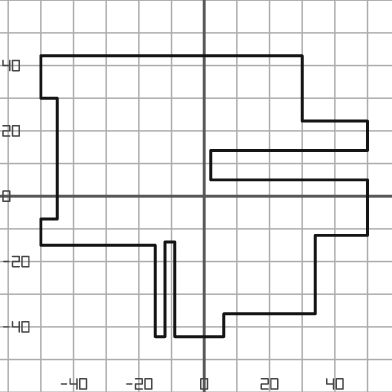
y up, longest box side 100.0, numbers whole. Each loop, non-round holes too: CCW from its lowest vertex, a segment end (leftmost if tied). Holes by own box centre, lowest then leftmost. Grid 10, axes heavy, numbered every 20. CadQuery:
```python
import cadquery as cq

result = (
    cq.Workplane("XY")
    .moveTo(-15.0, -43.0)
    .lineTo(-12.0, -43.0)
    .lineTo(-12.0, -14.0)
    .lineTo(-9.0, -14.0)
    .lineTo(-9.0, -43.0)
    .lineTo(6.0, -43.0)
    .lineTo(6.0, -36.0)
    .lineTo(34.0, -36.0)
    .lineTo(34.0, -12.0)
    .lineTo(50.0, -12.0)
    .lineTo(50.0, 5.0)
    .lineTo(2.0, 5.0)
    .lineTo(2.0, 14.0)
    .lineTo(50.0, 14.0)
    .lineTo(50.0, 23.0)
    .lineTo(30.0, 23.0)
    .lineTo(30.0, 43.0)
    .lineTo(-50.0, 43.0)
    .lineTo(-50.0, 30.0)
    .lineTo(-45.0, 30.0)
    .lineTo(-45.0, -7.0)
    .lineTo(-50.0, -7.0)
    .lineTo(-50.0, -15.0)
    .lineTo(-15.0, -15.0)
    .close()
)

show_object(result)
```